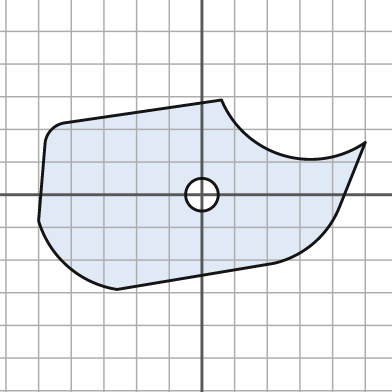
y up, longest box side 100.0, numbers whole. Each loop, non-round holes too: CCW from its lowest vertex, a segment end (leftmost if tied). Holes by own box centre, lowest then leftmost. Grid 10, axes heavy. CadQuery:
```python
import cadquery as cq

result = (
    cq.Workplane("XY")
    .moveTo(-26.0, -29.0)
    .lineTo(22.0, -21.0)
    .threePointArc((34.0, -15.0), (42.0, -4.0))
    .lineTo(50.0, 16.0)
    .threePointArc((25.0, 12.0), (6.0, 29.0))
    .lineTo(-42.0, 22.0)
    .threePointArc((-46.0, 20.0), (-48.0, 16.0))
    .lineTo(-50.0, -8.0)
    .threePointArc((-41.0, -22.0), (-26.0, -29.0))
    .close()
    .moveTo(0.0, 0.0)
    .circle(5.0)
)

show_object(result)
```